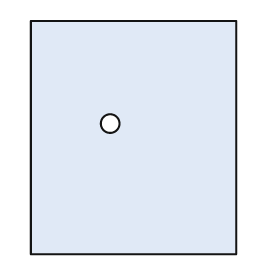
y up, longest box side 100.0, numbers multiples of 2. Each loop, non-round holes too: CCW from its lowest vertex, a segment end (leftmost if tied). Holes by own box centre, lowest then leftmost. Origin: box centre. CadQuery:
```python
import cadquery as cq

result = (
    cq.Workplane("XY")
    .moveTo(-44.0, -50.0)
    .lineTo(44.0, -50.0)
    .lineTo(44.0, 50.0)
    .lineTo(-44.0, 50.0)
    .close()
    .moveTo(-10.0, 6.0)
    .circle(4.0)
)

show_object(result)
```